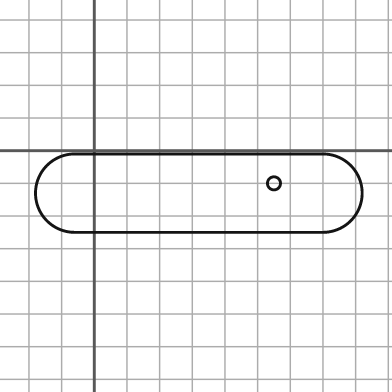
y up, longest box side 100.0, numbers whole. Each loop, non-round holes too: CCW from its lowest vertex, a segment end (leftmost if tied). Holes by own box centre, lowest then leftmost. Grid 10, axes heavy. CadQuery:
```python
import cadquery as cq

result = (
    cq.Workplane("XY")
    .moveTo(-6.0, -25.0)
    .lineTo(70.0, -25.0)
    .threePointArc((82.0, -13.0), (70.0, -1.0))
    .lineTo(-6.0, -1.0)
    .threePointArc((-18.0, -13.0), (-6.0, -25.0))
    .close()
    .moveTo(55.0, -10.0)
    .circle(2.0)
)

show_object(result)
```